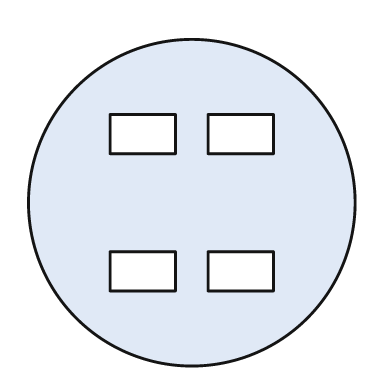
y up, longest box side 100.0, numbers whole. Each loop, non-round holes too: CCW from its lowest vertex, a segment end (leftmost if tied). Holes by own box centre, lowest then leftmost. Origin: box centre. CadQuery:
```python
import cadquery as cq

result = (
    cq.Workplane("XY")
    .moveTo(0.0, 0.0)
    .circle(50.0)
    .moveTo(-25.0, -27.0)
    .lineTo(-5.0, -27.0)
    .lineTo(-5.0, -15.0)
    .lineTo(-25.0, -15.0)
    .close()
    .moveTo(5.0, -27.0)
    .lineTo(25.0, -27.0)
    .lineTo(25.0, -15.0)
    .lineTo(5.0, -15.0)
    .close()
    .moveTo(-25.0, 15.0)
    .lineTo(-5.0, 15.0)
    .lineTo(-5.0, 27.0)
    .lineTo(-25.0, 27.0)
    .close()
    .moveTo(5.0, 15.0)
    .lineTo(25.0, 15.0)
    .lineTo(25.0, 27.0)
    .lineTo(5.0, 27.0)
    .close()
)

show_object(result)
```